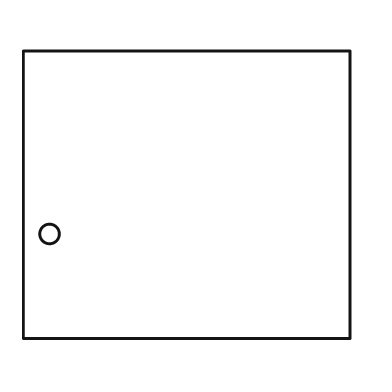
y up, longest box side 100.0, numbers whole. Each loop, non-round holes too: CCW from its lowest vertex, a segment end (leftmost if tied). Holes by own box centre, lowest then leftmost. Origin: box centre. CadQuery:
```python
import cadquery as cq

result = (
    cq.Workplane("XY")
    .moveTo(-50.0, -44.0)
    .lineTo(50.0, -44.0)
    .lineTo(50.0, 44.0)
    .lineTo(-50.0, 44.0)
    .close()
    .moveTo(-42.0, -12.0)
    .circle(3.0)
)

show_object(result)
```